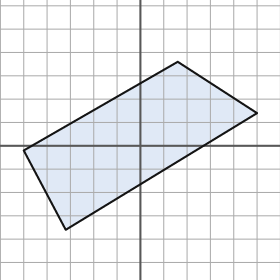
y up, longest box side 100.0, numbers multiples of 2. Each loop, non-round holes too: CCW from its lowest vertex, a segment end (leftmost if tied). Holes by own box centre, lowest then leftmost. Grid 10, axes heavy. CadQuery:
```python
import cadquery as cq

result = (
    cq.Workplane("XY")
    .moveTo(-32.0, -36.0)
    .lineTo(50.0, 14.0)
    .lineTo(16.0, 36.0)
    .lineTo(-50.0, -2.0)
    .close()
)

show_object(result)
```